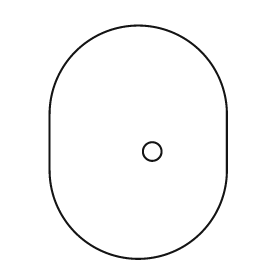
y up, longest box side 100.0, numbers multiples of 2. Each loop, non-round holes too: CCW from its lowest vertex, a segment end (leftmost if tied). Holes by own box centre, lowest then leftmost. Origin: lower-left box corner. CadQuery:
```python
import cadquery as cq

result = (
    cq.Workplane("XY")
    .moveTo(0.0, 38.0)
    .threePointArc((38.0, 0.0), (76.0, 38.0))
    .lineTo(76.0, 62.0)
    .threePointArc((38.0, 100.0), (0.0, 62.0))
    .close()
    .moveTo(44.0, 46.0)
    .circle(4.0)
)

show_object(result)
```